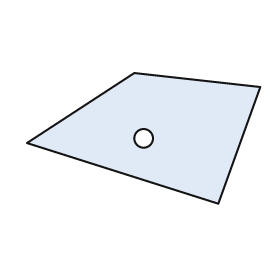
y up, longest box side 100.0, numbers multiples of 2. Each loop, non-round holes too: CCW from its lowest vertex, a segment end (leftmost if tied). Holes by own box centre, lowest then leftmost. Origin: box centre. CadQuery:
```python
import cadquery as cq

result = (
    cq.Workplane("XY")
    .moveTo(32.0, -28.0)
    .lineTo(50.0, 22.0)
    .lineTo(-4.0, 28.0)
    .lineTo(-50.0, -2.0)
    .close()
    .moveTo(0.0, 0.0)
    .circle(4.0)
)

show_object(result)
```